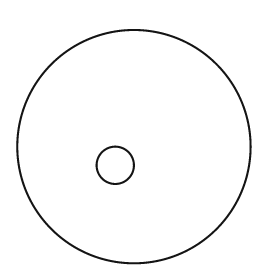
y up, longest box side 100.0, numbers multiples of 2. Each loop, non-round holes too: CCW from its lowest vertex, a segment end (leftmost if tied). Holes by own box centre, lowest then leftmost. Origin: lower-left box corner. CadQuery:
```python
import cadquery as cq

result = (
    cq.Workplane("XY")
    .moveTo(50.0, 50.0)
    .circle(50.0)
    .moveTo(42.0, 42.0)
    .circle(8.0)
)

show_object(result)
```